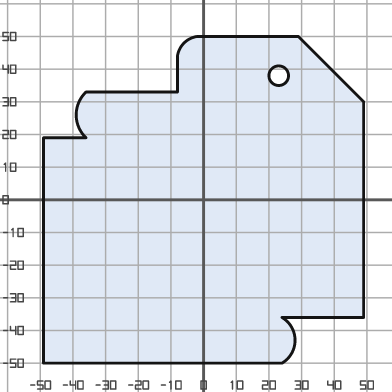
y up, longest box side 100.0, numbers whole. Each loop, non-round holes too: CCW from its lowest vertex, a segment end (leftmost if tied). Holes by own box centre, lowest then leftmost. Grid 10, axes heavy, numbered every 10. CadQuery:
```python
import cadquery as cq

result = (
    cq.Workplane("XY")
    .moveTo(-49.0, -50.0)
    .lineTo(24.0, -50.0)
    .threePointArc((28.0, -43.0), (24.0, -36.0))
    .lineTo(49.0, -36.0)
    .lineTo(49.0, 30.0)
    .lineTo(29.0, 50.0)
    .lineTo(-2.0, 50.0)
    .threePointArc((-6.0, 48.0), (-8.0, 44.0))
    .lineTo(-8.0, 33.0)
    .lineTo(-36.0, 33.0)
    .threePointArc((-39.0, 26.0), (-36.0, 19.0))
    .lineTo(-49.0, 19.0)
    .close()
    .moveTo(23.0, 38.0)
    .circle(3.0)
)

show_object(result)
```